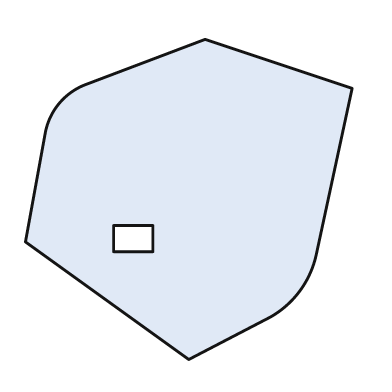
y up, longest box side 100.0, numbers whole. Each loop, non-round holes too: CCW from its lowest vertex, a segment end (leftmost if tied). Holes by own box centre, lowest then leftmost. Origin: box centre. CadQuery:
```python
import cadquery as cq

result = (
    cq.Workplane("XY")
    .moveTo(0.0, -49.0)
    .lineTo(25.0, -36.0)
    .threePointArc((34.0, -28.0), (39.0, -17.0))
    .lineTo(50.0, 34.0)
    .lineTo(5.0, 49.0)
    .lineTo(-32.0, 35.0)
    .threePointArc((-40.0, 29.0), (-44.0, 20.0))
    .lineTo(-50.0, -13.0)
    .close()
    .moveTo(-23.0, -16.0)
    .lineTo(-11.0, -16.0)
    .lineTo(-11.0, -8.0)
    .lineTo(-23.0, -8.0)
    .close()
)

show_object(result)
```